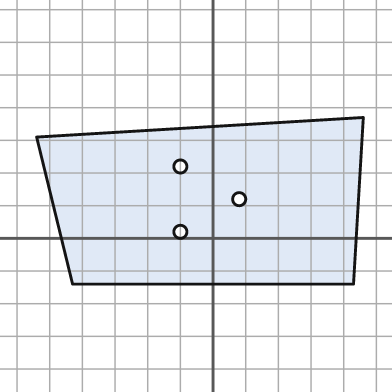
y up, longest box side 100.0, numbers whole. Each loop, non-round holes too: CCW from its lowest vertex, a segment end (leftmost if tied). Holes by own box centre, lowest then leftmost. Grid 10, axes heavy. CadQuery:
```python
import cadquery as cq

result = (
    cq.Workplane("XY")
    .moveTo(-43.0, -14.0)
    .lineTo(43.0, -14.0)
    .lineTo(46.0, 37.0)
    .lineTo(-54.0, 31.0)
    .close()
    .moveTo(-10.0, 2.0)
    .circle(2.0)
    .moveTo(8.0, 12.0)
    .circle(2.0)
    .moveTo(-10.0, 22.0)
    .circle(2.0)
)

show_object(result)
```